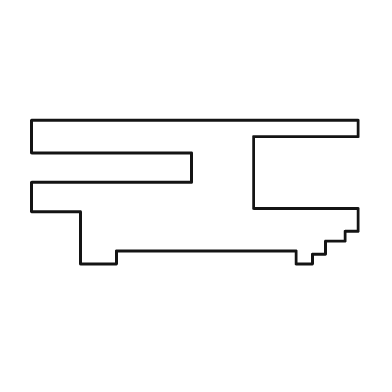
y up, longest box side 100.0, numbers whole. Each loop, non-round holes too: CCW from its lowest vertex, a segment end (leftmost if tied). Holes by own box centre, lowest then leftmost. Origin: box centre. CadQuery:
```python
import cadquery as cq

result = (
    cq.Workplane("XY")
    .moveTo(-35.0, -22.0)
    .lineTo(-24.0, -22.0)
    .lineTo(-24.0, -18.0)
    .lineTo(31.0, -18.0)
    .lineTo(31.0, -22.0)
    .lineTo(36.0, -22.0)
    .lineTo(36.0, -19.0)
    .lineTo(40.0, -19.0)
    .lineTo(40.0, -15.0)
    .lineTo(46.0, -15.0)
    .lineTo(46.0, -12.0)
    .lineTo(50.0, -12.0)
    .lineTo(50.0, -5.0)
    .lineTo(18.0, -5.0)
    .lineTo(18.0, 17.0)
    .lineTo(50.0, 17.0)
    .lineTo(50.0, 22.0)
    .lineTo(-50.0, 22.0)
    .lineTo(-50.0, 12.0)
    .lineTo(-1.0, 12.0)
    .lineTo(-1.0, 3.0)
    .lineTo(-50.0, 3.0)
    .lineTo(-50.0, -6.0)
    .lineTo(-35.0, -6.0)
    .close()
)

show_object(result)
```